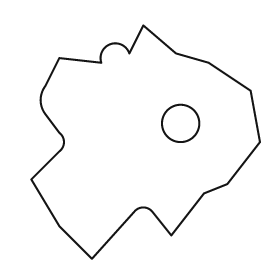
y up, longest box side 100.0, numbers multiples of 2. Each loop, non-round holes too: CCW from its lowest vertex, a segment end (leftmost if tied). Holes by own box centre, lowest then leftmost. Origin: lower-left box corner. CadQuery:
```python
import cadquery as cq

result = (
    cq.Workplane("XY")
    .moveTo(26.0, 0.0)
    .lineTo(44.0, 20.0)
    .threePointArc((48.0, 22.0), (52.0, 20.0))
    .lineTo(60.0, 10.0)
    .lineTo(74.0, 28.0)
    .lineTo(84.0, 32.0)
    .lineTo(98.0, 50.0)
    .lineTo(94.0, 72.0)
    .lineTo(76.0, 84.0)
    .lineTo(62.0, 88.0)
    .lineTo(48.0, 100.0)
    .lineTo(42.0, 88.0)
    .threePointArc((34.0, 92.0), (30.0, 84.0))
    .lineTo(12.0, 86.0)
    .lineTo(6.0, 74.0)
    .threePointArc((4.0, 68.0), (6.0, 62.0))
    .lineTo(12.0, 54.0)
    .threePointArc((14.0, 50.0), (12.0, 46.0))
    .lineTo(0.0, 34.0)
    .lineTo(12.0, 14.0)
    .close()
    .moveTo(64.0, 58.0)
    .circle(8.0)
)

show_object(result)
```